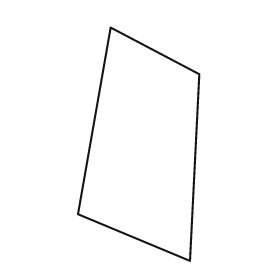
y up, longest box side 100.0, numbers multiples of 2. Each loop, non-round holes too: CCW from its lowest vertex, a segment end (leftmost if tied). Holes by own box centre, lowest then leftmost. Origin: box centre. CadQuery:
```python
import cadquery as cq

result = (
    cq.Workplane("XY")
    .moveTo(22.0, -50.0)
    .lineTo(26.0, 30.0)
    .lineTo(-12.0, 50.0)
    .lineTo(-26.0, -30.0)
    .close()
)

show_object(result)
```